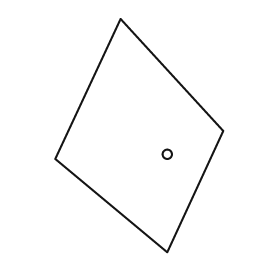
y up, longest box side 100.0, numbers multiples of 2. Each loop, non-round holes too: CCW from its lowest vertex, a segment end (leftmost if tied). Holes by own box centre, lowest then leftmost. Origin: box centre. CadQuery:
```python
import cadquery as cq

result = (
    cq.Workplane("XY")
    .moveTo(12.0, -50.0)
    .lineTo(36.0, 2.0)
    .lineTo(-8.0, 50.0)
    .lineTo(-36.0, -10.0)
    .close()
    .moveTo(12.0, -8.0)
    .circle(2.0)
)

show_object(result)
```